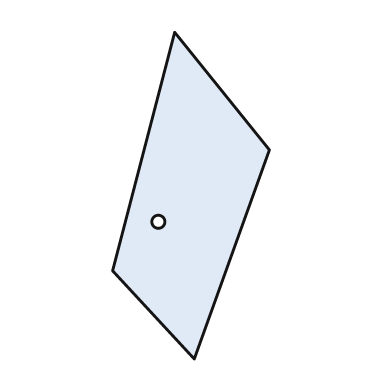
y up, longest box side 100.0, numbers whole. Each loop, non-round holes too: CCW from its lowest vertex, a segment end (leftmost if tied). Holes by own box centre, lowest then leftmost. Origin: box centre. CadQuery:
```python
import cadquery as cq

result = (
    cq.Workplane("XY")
    .moveTo(1.0, -50.0)
    .lineTo(24.0, 14.0)
    .lineTo(-5.0, 50.0)
    .lineTo(-24.0, -23.0)
    .close()
    .moveTo(-10.0, -8.0)
    .circle(2.0)
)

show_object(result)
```